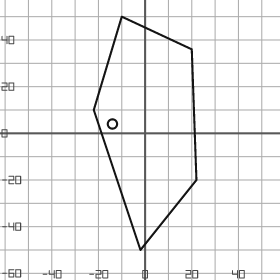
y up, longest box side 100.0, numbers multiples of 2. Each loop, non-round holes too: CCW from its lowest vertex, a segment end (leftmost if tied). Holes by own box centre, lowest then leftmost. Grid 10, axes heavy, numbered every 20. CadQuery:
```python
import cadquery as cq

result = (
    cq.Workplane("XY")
    .moveTo(-2.0, -50.0)
    .lineTo(22.0, -20.0)
    .lineTo(20.0, 36.0)
    .lineTo(-10.0, 50.0)
    .lineTo(-22.0, 10.0)
    .close()
    .moveTo(-14.0, 4.0)
    .circle(2.0)
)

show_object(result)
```